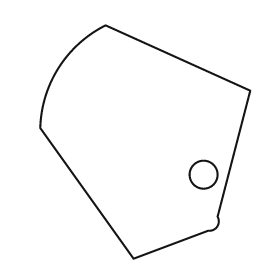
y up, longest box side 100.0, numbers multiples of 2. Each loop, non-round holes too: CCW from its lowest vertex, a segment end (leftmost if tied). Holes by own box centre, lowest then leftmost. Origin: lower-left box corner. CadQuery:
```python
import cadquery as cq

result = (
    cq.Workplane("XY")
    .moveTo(40.0, 0.0)
    .lineTo(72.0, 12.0)
    .threePointArc((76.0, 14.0), (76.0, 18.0))
    .lineTo(90.0, 72.0)
    .lineTo(28.0, 100.0)
    .threePointArc((8.0, 82.0), (0.0, 56.0))
    .close()
    .moveTo(70.0, 36.0)
    .circle(6.0)
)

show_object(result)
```